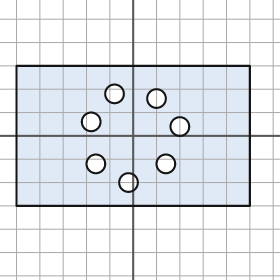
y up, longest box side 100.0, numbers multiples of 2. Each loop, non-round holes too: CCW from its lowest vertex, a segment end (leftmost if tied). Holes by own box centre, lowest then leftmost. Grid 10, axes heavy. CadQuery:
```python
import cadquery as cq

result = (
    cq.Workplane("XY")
    .moveTo(-50.0, -30.0)
    .lineTo(50.0, -30.0)
    .lineTo(50.0, 30.0)
    .lineTo(-50.0, 30.0)
    .close()
    .moveTo(-2.0, -20.0)
    .circle(4.0)
    .moveTo(-16.0, -12.0)
    .circle(4.0)
    .moveTo(14.0, -12.0)
    .circle(4.0)
    .moveTo(20.0, 4.0)
    .circle(4.0)
    .moveTo(-18.0, 6.0)
    .circle(4.0)
    .moveTo(10.0, 16.0)
    .circle(4.0)
    .moveTo(-8.0, 18.0)
    .circle(4.0)
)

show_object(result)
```